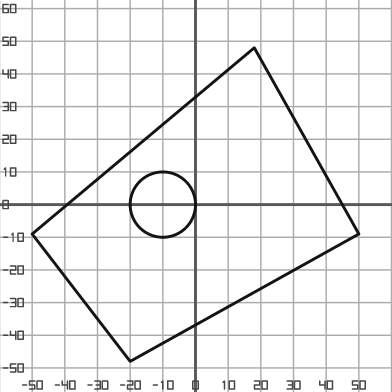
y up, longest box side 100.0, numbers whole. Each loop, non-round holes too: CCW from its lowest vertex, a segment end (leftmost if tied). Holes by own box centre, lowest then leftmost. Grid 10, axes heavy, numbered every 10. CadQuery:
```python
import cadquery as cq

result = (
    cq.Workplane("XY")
    .moveTo(-20.0, -48.0)
    .lineTo(50.0, -9.0)
    .lineTo(18.0, 48.0)
    .lineTo(-50.0, -9.0)
    .close()
    .moveTo(-10.0, 0.0)
    .circle(10.0)
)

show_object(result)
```